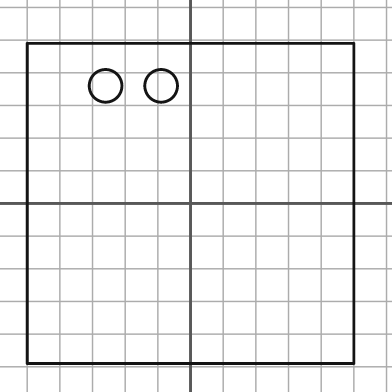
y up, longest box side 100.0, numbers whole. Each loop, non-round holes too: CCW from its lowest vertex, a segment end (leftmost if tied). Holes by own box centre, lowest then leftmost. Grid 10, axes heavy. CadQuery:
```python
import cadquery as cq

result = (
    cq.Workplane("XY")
    .moveTo(-50.0, -49.0)
    .lineTo(50.0, -49.0)
    .lineTo(50.0, 49.0)
    .lineTo(-50.0, 49.0)
    .close()
    .moveTo(-26.0, 36.0)
    .circle(5.0)
    .moveTo(-9.0, 36.0)
    .circle(5.0)
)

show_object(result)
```